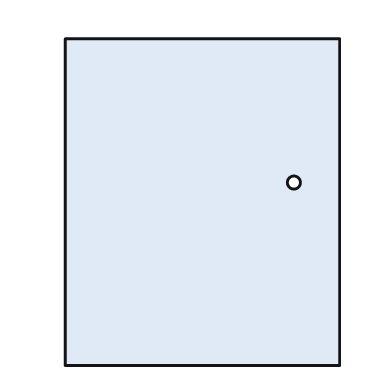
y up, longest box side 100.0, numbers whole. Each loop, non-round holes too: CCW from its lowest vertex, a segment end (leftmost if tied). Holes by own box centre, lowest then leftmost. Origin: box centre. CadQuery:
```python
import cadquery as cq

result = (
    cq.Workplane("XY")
    .moveTo(-42.0, -50.0)
    .lineTo(42.0, -50.0)
    .lineTo(42.0, 50.0)
    .lineTo(-42.0, 50.0)
    .close()
    .moveTo(28.0, 6.0)
    .circle(2.0)
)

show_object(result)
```